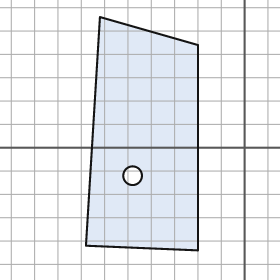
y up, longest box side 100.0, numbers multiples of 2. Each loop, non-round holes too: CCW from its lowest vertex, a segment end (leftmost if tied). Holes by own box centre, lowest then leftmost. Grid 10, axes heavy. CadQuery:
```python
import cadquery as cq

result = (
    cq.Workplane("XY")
    .moveTo(-20.0, -44.0)
    .lineTo(-20.0, 44.0)
    .lineTo(-62.0, 56.0)
    .lineTo(-68.0, -42.0)
    .close()
    .moveTo(-48.0, -12.0)
    .circle(4.0)
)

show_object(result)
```